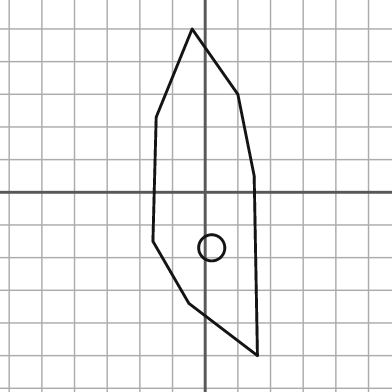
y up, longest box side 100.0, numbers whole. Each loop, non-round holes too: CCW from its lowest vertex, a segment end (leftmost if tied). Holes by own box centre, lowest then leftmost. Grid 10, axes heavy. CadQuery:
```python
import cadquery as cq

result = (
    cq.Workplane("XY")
    .moveTo(16.0, -50.0)
    .lineTo(15.0, 5.0)
    .lineTo(10.0, 30.0)
    .lineTo(-4.0, 50.0)
    .lineTo(-15.0, 23.0)
    .lineTo(-16.0, -15.0)
    .lineTo(-5.0, -34.0)
    .close()
    .moveTo(2.0, -17.0)
    .circle(4.0)
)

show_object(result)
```